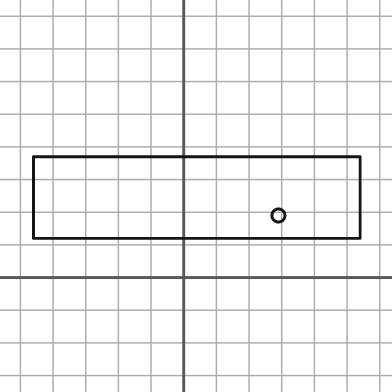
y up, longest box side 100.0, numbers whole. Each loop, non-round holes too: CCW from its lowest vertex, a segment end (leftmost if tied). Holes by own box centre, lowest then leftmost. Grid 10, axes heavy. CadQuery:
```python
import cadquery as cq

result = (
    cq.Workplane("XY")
    .moveTo(-46.0, 12.0)
    .lineTo(54.0, 12.0)
    .lineTo(54.0, 37.0)
    .lineTo(-46.0, 37.0)
    .close()
    .moveTo(29.0, 19.0)
    .circle(2.0)
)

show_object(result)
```